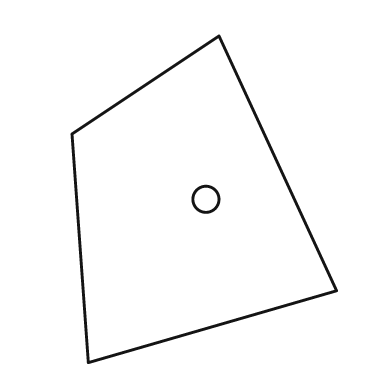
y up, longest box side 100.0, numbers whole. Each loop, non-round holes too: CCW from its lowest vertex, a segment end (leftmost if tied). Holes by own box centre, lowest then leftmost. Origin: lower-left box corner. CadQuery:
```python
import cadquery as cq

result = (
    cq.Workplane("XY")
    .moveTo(5.0, 0.0)
    .lineTo(81.0, 22.0)
    .lineTo(45.0, 100.0)
    .lineTo(0.0, 70.0)
    .close()
    .moveTo(41.0, 50.0)
    .circle(4.0)
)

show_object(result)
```